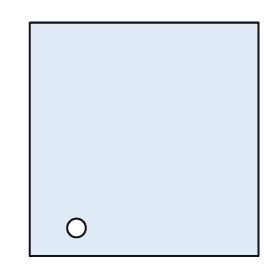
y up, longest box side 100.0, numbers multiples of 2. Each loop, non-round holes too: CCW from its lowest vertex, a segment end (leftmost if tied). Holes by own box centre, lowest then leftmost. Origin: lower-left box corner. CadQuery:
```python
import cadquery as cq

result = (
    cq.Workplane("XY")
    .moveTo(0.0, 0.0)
    .lineTo(98.0, 0.0)
    .lineTo(98.0, 100.0)
    .lineTo(0.0, 100.0)
    .close()
    .moveTo(20.0, 12.0)
    .circle(4.0)
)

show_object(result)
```